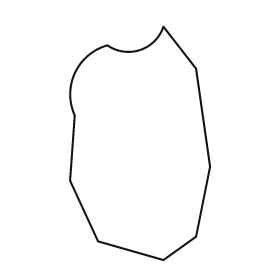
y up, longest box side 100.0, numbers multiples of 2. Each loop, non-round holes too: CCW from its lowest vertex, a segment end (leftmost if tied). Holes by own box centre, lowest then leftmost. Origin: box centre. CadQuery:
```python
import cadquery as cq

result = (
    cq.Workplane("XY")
    .moveTo(10.0, -50.0)
    .lineTo(24.0, -40.0)
    .lineTo(30.0, -10.0)
    .lineTo(24.0, 32.0)
    .lineTo(10.0, 50.0)
    .threePointArc((0.0, 40.0), (-14.0, 42.0))
    .threePointArc((-28.0, 30.0), (-28.0, 12.0))
    .lineTo(-30.0, -16.0)
    .lineTo(-18.0, -42.0)
    .close()
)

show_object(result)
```